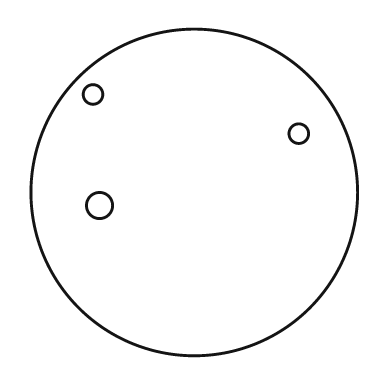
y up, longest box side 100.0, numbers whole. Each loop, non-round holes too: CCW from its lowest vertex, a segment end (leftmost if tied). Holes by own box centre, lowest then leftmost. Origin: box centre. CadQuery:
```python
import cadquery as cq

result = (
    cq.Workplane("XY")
    .moveTo(0.0, 0.0)
    .circle(50.0)
    .moveTo(-29.0, -4.0)
    .circle(4.0)
    .moveTo(32.0, 18.0)
    .circle(3.0)
    .moveTo(-31.0, 30.0)
    .circle(3.0)
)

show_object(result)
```